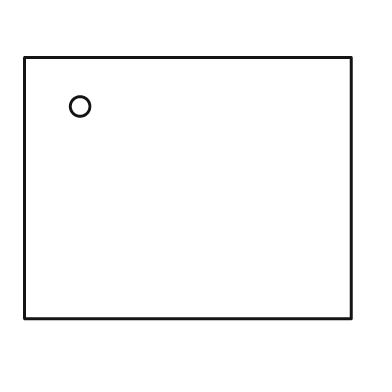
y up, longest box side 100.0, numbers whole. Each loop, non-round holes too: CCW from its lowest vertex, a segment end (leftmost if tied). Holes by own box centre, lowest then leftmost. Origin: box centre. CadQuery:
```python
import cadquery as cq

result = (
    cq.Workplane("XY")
    .moveTo(-50.0, -40.0)
    .lineTo(50.0, -40.0)
    .lineTo(50.0, 40.0)
    .lineTo(-50.0, 40.0)
    .close()
    .moveTo(-33.0, 25.0)
    .circle(3.0)
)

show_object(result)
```